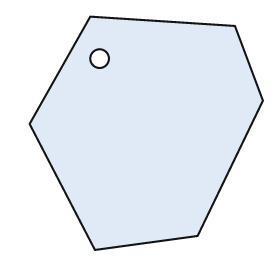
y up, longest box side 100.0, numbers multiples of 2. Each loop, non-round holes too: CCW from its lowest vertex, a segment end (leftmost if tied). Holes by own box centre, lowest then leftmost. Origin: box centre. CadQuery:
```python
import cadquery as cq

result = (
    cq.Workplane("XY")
    .moveTo(-22.0, -50.0)
    .lineTo(22.0, -44.0)
    .lineTo(50.0, 14.0)
    .lineTo(38.0, 46.0)
    .lineTo(-24.0, 50.0)
    .lineTo(-50.0, 4.0)
    .close()
    .moveTo(-20.0, 32.0)
    .circle(4.0)
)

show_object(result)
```